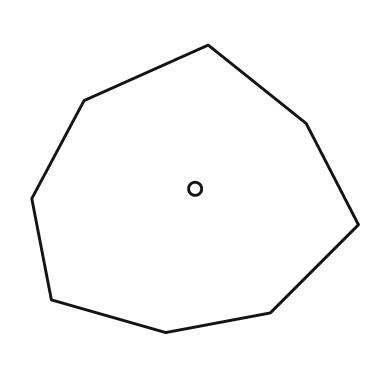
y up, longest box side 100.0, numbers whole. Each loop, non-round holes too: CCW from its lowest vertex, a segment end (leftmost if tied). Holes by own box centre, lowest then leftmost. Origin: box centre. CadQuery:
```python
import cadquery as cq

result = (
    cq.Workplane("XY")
    .moveTo(-9.0, -44.0)
    .lineTo(23.0, -38.0)
    .lineTo(50.0, -11.0)
    .lineTo(34.0, 20.0)
    .lineTo(4.0, 44.0)
    .lineTo(-34.0, 27.0)
    .lineTo(-50.0, -3.0)
    .lineTo(-44.0, -34.0)
    .close()
    .moveTo(0.0, 0.0)
    .circle(2.0)
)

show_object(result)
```